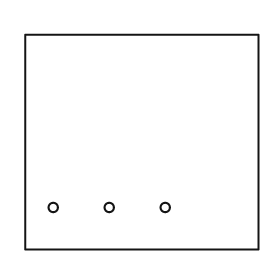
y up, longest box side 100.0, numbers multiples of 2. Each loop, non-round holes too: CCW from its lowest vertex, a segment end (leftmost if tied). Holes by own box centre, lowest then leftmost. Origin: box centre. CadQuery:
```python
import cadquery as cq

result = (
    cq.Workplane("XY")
    .moveTo(-50.0, -46.0)
    .lineTo(50.0, -46.0)
    .lineTo(50.0, 46.0)
    .lineTo(-50.0, 46.0)
    .close()
    .moveTo(-38.0, -28.0)
    .circle(2.0)
    .moveTo(-14.0, -28.0)
    .circle(2.0)
    .moveTo(10.0, -28.0)
    .circle(2.0)
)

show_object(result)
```